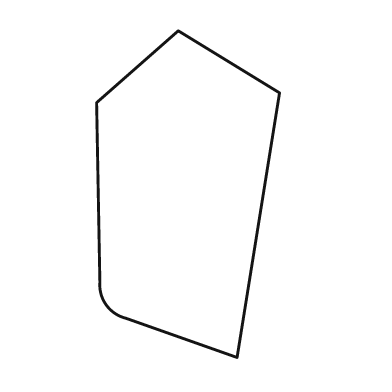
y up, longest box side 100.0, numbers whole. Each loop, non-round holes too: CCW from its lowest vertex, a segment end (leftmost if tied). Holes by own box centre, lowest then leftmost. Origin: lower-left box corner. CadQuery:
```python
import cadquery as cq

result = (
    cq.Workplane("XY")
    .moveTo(43.0, 0.0)
    .lineTo(56.0, 81.0)
    .lineTo(25.0, 100.0)
    .lineTo(0.0, 78.0)
    .lineTo(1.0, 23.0)
    .threePointArc((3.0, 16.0), (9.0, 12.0))
    .close()
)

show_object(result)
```